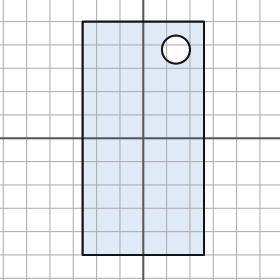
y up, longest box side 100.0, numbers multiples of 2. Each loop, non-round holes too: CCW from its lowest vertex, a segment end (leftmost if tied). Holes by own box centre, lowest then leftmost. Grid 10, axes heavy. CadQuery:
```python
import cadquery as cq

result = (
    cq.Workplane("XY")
    .moveTo(-26.0, -50.0)
    .lineTo(26.0, -50.0)
    .lineTo(26.0, 50.0)
    .lineTo(-26.0, 50.0)
    .close()
    .moveTo(14.0, 38.0)
    .circle(6.0)
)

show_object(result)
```